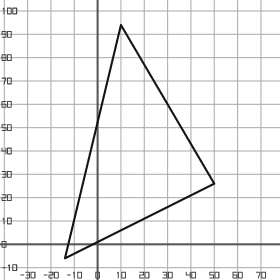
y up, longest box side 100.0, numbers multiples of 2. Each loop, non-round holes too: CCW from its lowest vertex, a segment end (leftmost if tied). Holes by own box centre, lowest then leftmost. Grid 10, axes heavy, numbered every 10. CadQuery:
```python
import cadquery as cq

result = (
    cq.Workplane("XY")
    .moveTo(-14.0, -6.0)
    .lineTo(50.0, 26.0)
    .lineTo(10.0, 94.0)
    .close()
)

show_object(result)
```